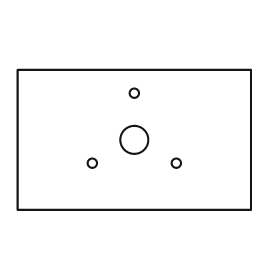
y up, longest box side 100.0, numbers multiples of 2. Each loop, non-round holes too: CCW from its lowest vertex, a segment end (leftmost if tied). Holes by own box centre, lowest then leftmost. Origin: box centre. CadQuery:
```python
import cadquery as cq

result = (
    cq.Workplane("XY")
    .moveTo(-50.0, -30.0)
    .lineTo(50.0, -30.0)
    .lineTo(50.0, 30.0)
    .lineTo(-50.0, 30.0)
    .close()
    .moveTo(-18.0, -10.0)
    .circle(2.0)
    .moveTo(18.0, -10.0)
    .circle(2.0)
    .moveTo(0.0, 0.0)
    .circle(6.0)
    .moveTo(0.0, 20.0)
    .circle(2.0)
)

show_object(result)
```